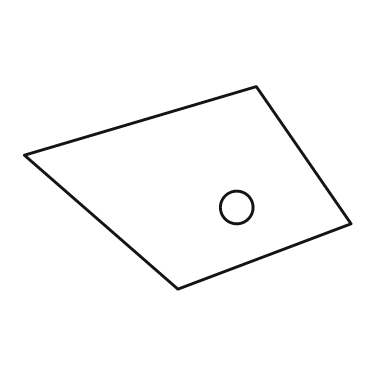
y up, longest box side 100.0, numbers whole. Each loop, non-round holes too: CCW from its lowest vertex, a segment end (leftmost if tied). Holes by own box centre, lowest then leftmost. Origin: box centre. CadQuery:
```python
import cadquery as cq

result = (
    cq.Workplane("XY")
    .moveTo(-3.0, -31.0)
    .lineTo(50.0, -11.0)
    .lineTo(21.0, 31.0)
    .lineTo(-50.0, 10.0)
    .close()
    .moveTo(15.0, -6.0)
    .circle(5.0)
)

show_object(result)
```